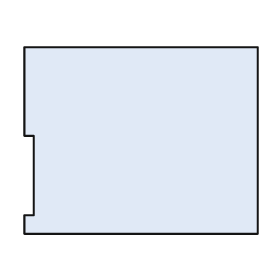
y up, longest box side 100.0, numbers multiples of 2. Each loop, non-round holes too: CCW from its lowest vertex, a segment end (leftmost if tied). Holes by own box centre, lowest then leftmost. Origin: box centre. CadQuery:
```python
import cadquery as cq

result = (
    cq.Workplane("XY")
    .moveTo(-50.0, -40.0)
    .lineTo(50.0, -40.0)
    .lineTo(50.0, 40.0)
    .lineTo(-50.0, 40.0)
    .lineTo(-50.0, 2.0)
    .lineTo(-46.0, 2.0)
    .lineTo(-46.0, -32.0)
    .lineTo(-50.0, -32.0)
    .close()
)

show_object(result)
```